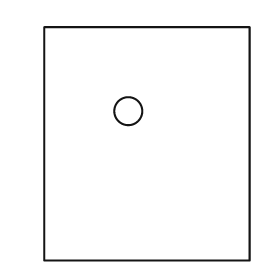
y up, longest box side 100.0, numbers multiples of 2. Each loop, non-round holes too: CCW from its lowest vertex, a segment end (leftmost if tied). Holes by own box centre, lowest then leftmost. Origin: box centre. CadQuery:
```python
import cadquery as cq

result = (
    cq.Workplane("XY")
    .moveTo(-44.0, -50.0)
    .lineTo(44.0, -50.0)
    .lineTo(44.0, 50.0)
    .lineTo(-44.0, 50.0)
    .close()
    .moveTo(-8.0, 14.0)
    .circle(6.0)
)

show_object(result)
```